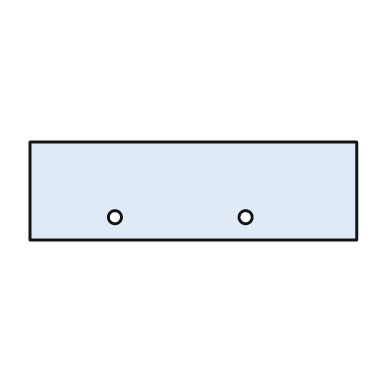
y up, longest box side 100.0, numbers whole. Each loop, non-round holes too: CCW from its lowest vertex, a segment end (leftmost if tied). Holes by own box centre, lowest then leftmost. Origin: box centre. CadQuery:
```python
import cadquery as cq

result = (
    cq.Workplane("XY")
    .moveTo(-50.0, -15.0)
    .lineTo(50.0, -15.0)
    .lineTo(50.0, 15.0)
    .lineTo(-50.0, 15.0)
    .close()
    .moveTo(-24.0, -8.0)
    .circle(2.0)
    .moveTo(16.0, -8.0)
    .circle(2.0)
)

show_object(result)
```